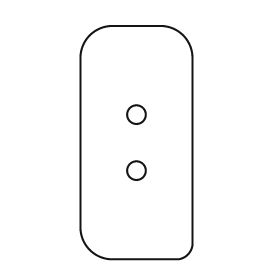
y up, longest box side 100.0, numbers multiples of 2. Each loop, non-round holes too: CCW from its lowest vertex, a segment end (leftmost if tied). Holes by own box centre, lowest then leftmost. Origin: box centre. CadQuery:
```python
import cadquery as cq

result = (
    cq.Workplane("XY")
    .moveTo(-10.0, -50.0)
    .lineTo(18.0, -50.0)
    .threePointArc((22.0, -48.0), (24.0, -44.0))
    .lineTo(24.0, 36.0)
    .threePointArc((20.0, 46.0), (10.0, 50.0))
    .lineTo(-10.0, 50.0)
    .threePointArc((-20.0, 46.0), (-24.0, 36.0))
    .lineTo(-24.0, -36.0)
    .threePointArc((-20.0, -46.0), (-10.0, -50.0))
    .close()
    .moveTo(0.0, -12.0)
    .circle(4.0)
    .moveTo(0.0, 12.0)
    .circle(4.0)
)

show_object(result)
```